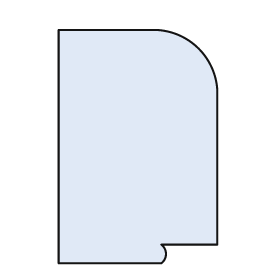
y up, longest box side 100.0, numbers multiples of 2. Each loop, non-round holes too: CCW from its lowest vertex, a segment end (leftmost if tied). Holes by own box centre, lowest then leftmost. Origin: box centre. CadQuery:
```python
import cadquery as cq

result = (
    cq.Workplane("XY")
    .moveTo(-34.0, -50.0)
    .lineTo(10.0, -50.0)
    .threePointArc((12.0, -46.0), (10.0, -42.0))
    .lineTo(34.0, -42.0)
    .lineTo(34.0, 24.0)
    .threePointArc((26.0, 42.0), (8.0, 50.0))
    .lineTo(-34.0, 50.0)
    .close()
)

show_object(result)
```